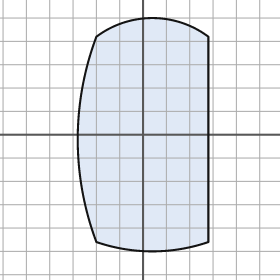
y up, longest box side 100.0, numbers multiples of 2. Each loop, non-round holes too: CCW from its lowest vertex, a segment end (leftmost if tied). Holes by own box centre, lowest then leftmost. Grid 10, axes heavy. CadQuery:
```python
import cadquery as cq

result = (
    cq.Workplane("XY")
    .moveTo(-20.0, -46.0)
    .threePointArc((4.0, -50.0), (28.0, -46.0))
    .lineTo(28.0, 42.0)
    .threePointArc((4.0, 50.0), (-20.0, 42.0))
    .threePointArc((-28.0, -2.0), (-20.0, -46.0))
    .close()
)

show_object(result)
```